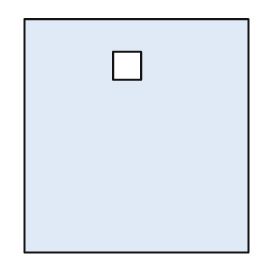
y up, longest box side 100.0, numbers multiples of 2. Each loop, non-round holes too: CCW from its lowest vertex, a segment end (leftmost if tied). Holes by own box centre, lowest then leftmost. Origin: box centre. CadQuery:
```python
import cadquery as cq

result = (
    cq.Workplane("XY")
    .moveTo(-48.0, -50.0)
    .lineTo(48.0, -50.0)
    .lineTo(48.0, 50.0)
    .lineTo(-48.0, 50.0)
    .close()
    .moveTo(-10.0, 24.0)
    .lineTo(2.0, 24.0)
    .lineTo(2.0, 36.0)
    .lineTo(-10.0, 36.0)
    .close()
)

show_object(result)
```